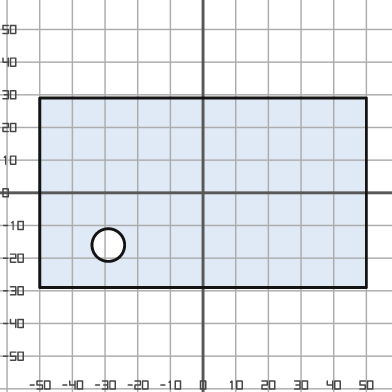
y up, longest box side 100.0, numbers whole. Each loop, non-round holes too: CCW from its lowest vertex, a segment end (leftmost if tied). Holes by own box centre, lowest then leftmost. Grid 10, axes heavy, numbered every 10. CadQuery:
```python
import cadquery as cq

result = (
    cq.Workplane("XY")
    .moveTo(-50.0, -29.0)
    .lineTo(50.0, -29.0)
    .lineTo(50.0, 29.0)
    .lineTo(-50.0, 29.0)
    .close()
    .moveTo(-29.0, -16.0)
    .circle(5.0)
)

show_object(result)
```